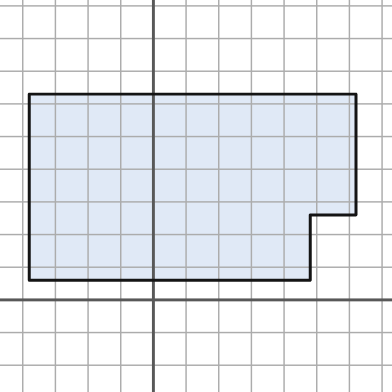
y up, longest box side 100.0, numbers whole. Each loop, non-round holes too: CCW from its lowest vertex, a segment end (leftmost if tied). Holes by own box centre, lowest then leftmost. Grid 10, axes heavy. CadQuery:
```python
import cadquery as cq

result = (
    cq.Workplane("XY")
    .moveTo(-38.0, 6.0)
    .lineTo(48.0, 6.0)
    .lineTo(48.0, 26.0)
    .lineTo(62.0, 26.0)
    .lineTo(62.0, 63.0)
    .lineTo(-38.0, 63.0)
    .close()
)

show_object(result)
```